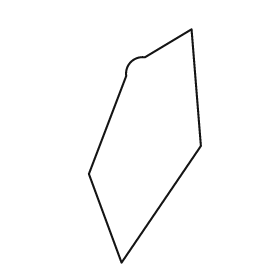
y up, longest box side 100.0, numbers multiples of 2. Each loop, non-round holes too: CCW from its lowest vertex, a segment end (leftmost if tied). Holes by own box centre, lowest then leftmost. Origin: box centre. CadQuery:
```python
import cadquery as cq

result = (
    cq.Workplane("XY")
    .moveTo(-10.0, -50.0)
    .lineTo(24.0, 0.0)
    .lineTo(20.0, 50.0)
    .lineTo(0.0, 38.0)
    .threePointArc((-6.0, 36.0), (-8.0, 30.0))
    .lineTo(-24.0, -12.0)
    .close()
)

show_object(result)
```